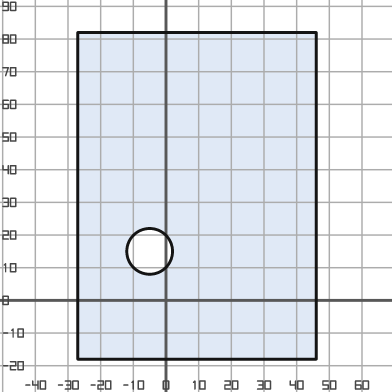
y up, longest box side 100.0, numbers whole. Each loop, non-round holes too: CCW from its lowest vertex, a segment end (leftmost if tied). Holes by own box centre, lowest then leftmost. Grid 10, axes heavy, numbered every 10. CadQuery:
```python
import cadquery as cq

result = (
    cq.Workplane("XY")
    .moveTo(-27.0, -18.0)
    .lineTo(46.0, -18.0)
    .lineTo(46.0, 82.0)
    .lineTo(-27.0, 82.0)
    .close()
    .moveTo(-5.0, 15.0)
    .circle(7.0)
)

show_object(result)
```